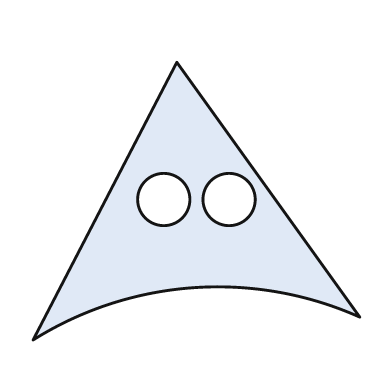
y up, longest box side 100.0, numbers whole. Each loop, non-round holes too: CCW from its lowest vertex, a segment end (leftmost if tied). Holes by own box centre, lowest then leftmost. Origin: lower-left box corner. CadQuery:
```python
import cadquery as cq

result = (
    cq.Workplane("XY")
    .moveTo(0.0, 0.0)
    .threePointArc((49.0, 16.0), (100.0, 7.0))
    .lineTo(44.0, 85.0)
    .close()
    .moveTo(40.0, 43.0)
    .circle(8.0)
    .moveTo(60.0, 43.0)
    .circle(8.0)
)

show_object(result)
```